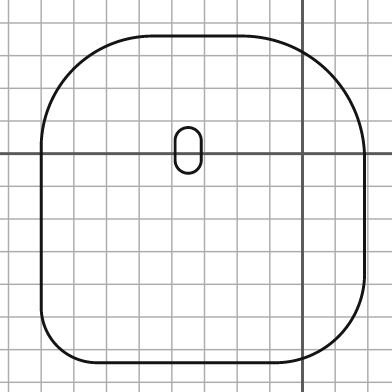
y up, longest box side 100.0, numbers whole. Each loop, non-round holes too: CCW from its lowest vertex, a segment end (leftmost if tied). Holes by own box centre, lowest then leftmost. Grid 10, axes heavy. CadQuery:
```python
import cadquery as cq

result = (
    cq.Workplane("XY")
    .moveTo(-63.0, -64.0)
    .lineTo(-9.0, -64.0)
    .threePointArc((11.0, -56.0), (19.0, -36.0))
    .lineTo(19.0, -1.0)
    .threePointArc((8.0, 25.0), (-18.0, 36.0))
    .lineTo(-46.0, 36.0)
    .threePointArc((-70.0, 26.0), (-80.0, 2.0))
    .lineTo(-80.0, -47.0)
    .threePointArc((-75.0, -59.0), (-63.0, -64.0))
    .close()
    .moveTo(-39.0, -2.0)
    .threePointArc((-35.0, -6.0), (-31.0, -2.0))
    .lineTo(-31.0, 4.0)
    .threePointArc((-35.0, 8.0), (-39.0, 4.0))
    .close()
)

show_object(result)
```